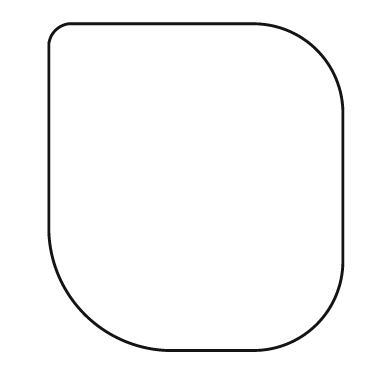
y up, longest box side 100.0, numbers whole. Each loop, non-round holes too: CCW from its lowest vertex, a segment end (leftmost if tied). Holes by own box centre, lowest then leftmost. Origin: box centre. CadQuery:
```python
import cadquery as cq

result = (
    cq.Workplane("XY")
    .moveTo(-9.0, -50.0)
    .lineTo(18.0, -50.0)
    .threePointArc((37.0, -42.0), (45.0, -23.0))
    .lineTo(45.0, 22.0)
    .threePointArc((37.0, 42.0), (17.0, 50.0))
    .lineTo(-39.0, 50.0)
    .threePointArc((-43.0, 48.0), (-45.0, 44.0))
    .lineTo(-45.0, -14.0)
    .threePointArc((-34.0, -39.0), (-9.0, -50.0))
    .close()
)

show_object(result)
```